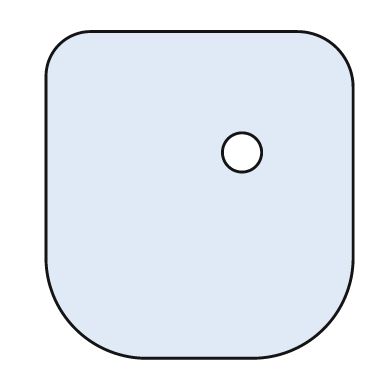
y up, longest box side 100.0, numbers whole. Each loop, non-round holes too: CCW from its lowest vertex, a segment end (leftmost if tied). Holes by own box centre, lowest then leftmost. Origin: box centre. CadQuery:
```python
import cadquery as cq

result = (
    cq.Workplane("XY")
    .moveTo(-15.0, -50.0)
    .lineTo(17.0, -50.0)
    .threePointArc((38.0, -41.0), (47.0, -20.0))
    .lineTo(47.0, 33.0)
    .threePointArc((42.0, 45.0), (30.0, 50.0))
    .lineTo(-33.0, 50.0)
    .threePointArc((-43.0, 46.0), (-47.0, 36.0))
    .lineTo(-47.0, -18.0)
    .threePointArc((-38.0, -41.0), (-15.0, -50.0))
    .close()
    .moveTo(13.0, 13.0)
    .circle(6.0)
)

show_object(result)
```